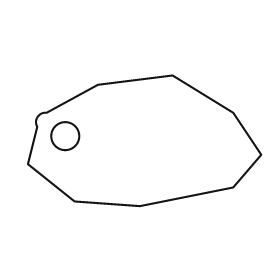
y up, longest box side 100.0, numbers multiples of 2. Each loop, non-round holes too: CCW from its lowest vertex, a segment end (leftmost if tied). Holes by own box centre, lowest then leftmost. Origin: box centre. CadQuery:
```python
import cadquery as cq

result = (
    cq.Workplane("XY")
    .moveTo(-2.0, -28.0)
    .lineTo(38.0, -20.0)
    .lineTo(50.0, -6.0)
    .lineTo(38.0, 12.0)
    .lineTo(12.0, 28.0)
    .lineTo(-20.0, 24.0)
    .lineTo(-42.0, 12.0)
    .threePointArc((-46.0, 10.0), (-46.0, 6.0))
    .lineTo(-50.0, -10.0)
    .lineTo(-30.0, -26.0)
    .close()
    .moveTo(-34.0, 2.0)
    .circle(6.0)
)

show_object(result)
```